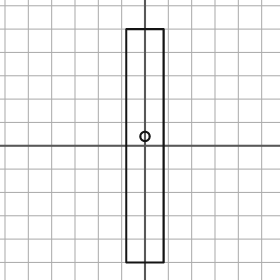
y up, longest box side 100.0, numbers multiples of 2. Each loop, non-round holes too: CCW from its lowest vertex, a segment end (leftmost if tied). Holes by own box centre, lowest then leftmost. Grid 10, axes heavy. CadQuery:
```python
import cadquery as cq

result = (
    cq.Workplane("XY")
    .moveTo(-8.0, -50.0)
    .lineTo(8.0, -50.0)
    .lineTo(8.0, 50.0)
    .lineTo(-8.0, 50.0)
    .close()
    .moveTo(0.0, 4.0)
    .circle(2.0)
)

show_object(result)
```